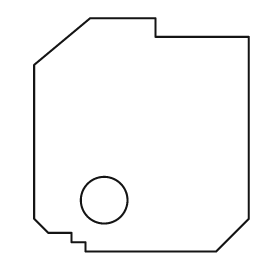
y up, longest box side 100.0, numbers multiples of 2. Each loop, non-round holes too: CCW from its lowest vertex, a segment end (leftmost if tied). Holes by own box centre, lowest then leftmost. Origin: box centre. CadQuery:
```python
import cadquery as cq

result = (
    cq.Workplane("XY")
    .moveTo(-24.0, -50.0)
    .lineTo(32.0, -50.0)
    .lineTo(46.0, -36.0)
    .lineTo(46.0, 42.0)
    .lineTo(6.0, 42.0)
    .lineTo(6.0, 50.0)
    .lineTo(-22.0, 50.0)
    .lineTo(-46.0, 30.0)
    .lineTo(-46.0, -36.0)
    .lineTo(-40.0, -42.0)
    .lineTo(-30.0, -42.0)
    .lineTo(-30.0, -46.0)
    .lineTo(-24.0, -46.0)
    .close()
    .moveTo(-16.0, -28.0)
    .circle(10.0)
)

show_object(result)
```